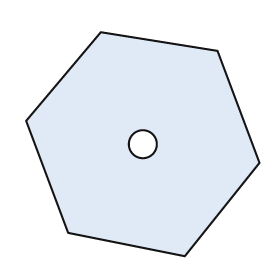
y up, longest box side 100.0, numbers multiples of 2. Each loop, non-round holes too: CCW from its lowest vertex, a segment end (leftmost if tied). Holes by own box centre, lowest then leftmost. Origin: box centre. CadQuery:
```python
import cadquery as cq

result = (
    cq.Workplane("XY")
    .moveTo(18.0, -48.0)
    .lineTo(50.0, -8.0)
    .lineTo(32.0, 40.0)
    .lineTo(-18.0, 48.0)
    .lineTo(-50.0, 10.0)
    .lineTo(-32.0, -38.0)
    .close()
    .moveTo(0.0, 0.0)
    .circle(6.0)
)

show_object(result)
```